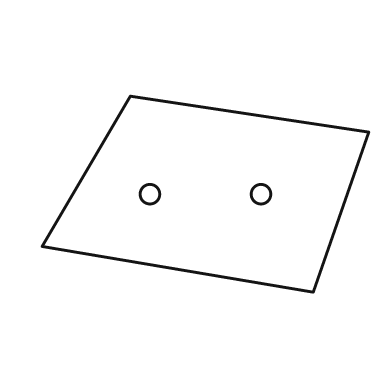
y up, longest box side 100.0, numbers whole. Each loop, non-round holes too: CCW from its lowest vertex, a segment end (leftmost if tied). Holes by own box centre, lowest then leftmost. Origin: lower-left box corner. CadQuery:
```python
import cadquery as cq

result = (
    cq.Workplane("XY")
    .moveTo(83.0, 0.0)
    .lineTo(100.0, 49.0)
    .lineTo(27.0, 60.0)
    .lineTo(0.0, 14.0)
    .close()
    .moveTo(33.0, 30.0)
    .circle(3.0)
    .moveTo(67.0, 30.0)
    .circle(3.0)
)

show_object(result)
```